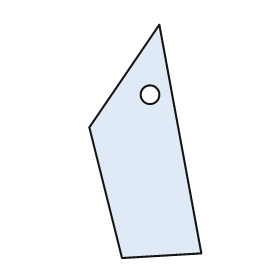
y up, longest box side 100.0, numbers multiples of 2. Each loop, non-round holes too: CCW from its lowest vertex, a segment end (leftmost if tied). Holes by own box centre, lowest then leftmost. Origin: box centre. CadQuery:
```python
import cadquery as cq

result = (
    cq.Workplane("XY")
    .moveTo(-10.0, -50.0)
    .lineTo(24.0, -48.0)
    .lineTo(6.0, 50.0)
    .lineTo(-24.0, 6.0)
    .close()
    .moveTo(2.0, 20.0)
    .circle(4.0)
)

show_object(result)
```